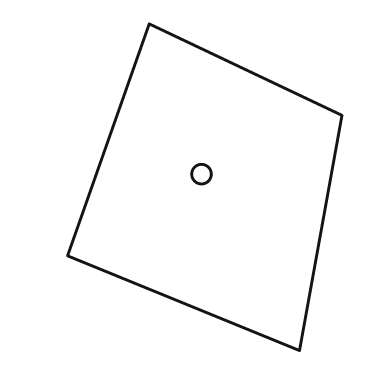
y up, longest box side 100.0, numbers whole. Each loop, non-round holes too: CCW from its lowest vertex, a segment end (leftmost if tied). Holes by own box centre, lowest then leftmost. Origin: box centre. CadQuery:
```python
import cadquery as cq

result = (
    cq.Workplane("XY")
    .moveTo(29.0, -50.0)
    .lineTo(42.0, 22.0)
    .lineTo(-17.0, 50.0)
    .lineTo(-42.0, -21.0)
    .close()
    .moveTo(-1.0, 4.0)
    .circle(3.0)
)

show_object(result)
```